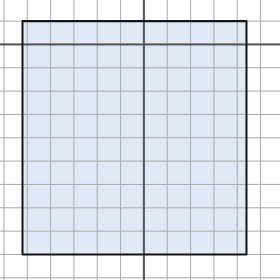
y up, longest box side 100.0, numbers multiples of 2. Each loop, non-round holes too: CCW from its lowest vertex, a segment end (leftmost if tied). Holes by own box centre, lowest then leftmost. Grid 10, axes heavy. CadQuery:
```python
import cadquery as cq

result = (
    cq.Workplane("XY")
    .moveTo(-52.0, -90.0)
    .lineTo(44.0, -90.0)
    .lineTo(44.0, 10.0)
    .lineTo(-52.0, 10.0)
    .close()
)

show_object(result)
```